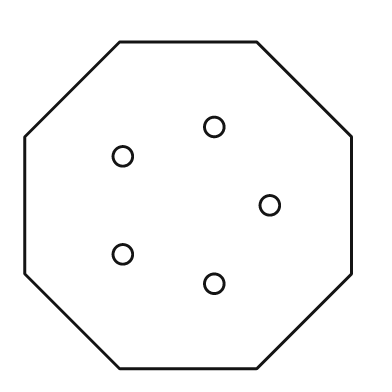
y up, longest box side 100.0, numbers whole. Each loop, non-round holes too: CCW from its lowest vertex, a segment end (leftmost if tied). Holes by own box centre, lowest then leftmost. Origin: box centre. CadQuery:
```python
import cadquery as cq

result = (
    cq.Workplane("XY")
    .moveTo(-21.0, -50.0)
    .lineTo(21.0, -50.0)
    .lineTo(50.0, -21.0)
    .lineTo(50.0, 21.0)
    .lineTo(21.0, 50.0)
    .lineTo(-21.0, 50.0)
    .lineTo(-50.0, 21.0)
    .lineTo(-50.0, -21.0)
    .close()
    .moveTo(8.0, -24.0)
    .circle(3.0)
    .moveTo(-20.0, -15.0)
    .circle(3.0)
    .moveTo(25.0, 0.0)
    .circle(3.0)
    .moveTo(-20.0, 15.0)
    .circle(3.0)
    .moveTo(8.0, 24.0)
    .circle(3.0)
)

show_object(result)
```